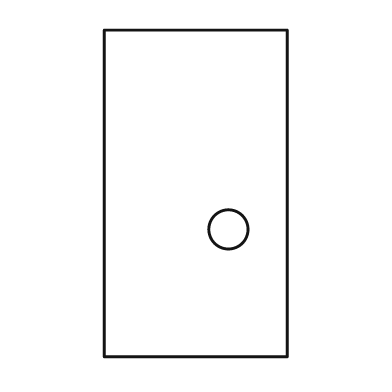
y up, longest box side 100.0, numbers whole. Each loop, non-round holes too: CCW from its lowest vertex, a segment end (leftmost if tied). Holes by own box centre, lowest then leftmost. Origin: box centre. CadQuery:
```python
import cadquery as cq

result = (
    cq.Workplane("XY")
    .moveTo(-28.0, -50.0)
    .lineTo(28.0, -50.0)
    .lineTo(28.0, 50.0)
    .lineTo(-28.0, 50.0)
    .close()
    .moveTo(10.0, -11.0)
    .circle(6.0)
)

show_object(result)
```